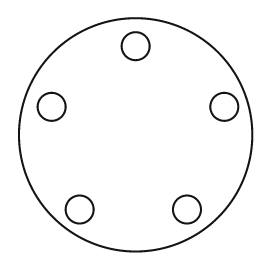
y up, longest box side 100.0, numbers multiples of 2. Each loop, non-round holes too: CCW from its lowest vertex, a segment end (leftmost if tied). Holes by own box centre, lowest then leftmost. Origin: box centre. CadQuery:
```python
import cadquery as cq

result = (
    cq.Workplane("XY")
    .moveTo(0.0, 0.0)
    .circle(50.0)
    .moveTo(-24.0, -32.0)
    .circle(6.0)
    .moveTo(22.0, -32.0)
    .circle(6.0)
    .moveTo(-36.0, 12.0)
    .circle(6.0)
    .moveTo(38.0, 12.0)
    .circle(6.0)
    .moveTo(0.0, 38.0)
    .circle(6.0)
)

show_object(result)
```